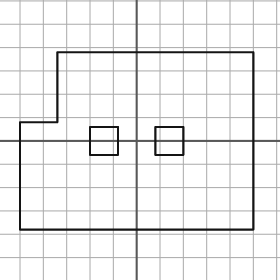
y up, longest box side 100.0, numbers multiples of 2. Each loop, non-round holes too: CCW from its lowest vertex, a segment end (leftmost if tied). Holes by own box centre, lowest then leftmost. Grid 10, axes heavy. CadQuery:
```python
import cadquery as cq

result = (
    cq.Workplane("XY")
    .moveTo(-50.0, -38.0)
    .lineTo(50.0, -38.0)
    .lineTo(50.0, 38.0)
    .lineTo(-34.0, 38.0)
    .lineTo(-34.0, 8.0)
    .lineTo(-50.0, 8.0)
    .close()
    .moveTo(-20.0, -6.0)
    .lineTo(-8.0, -6.0)
    .lineTo(-8.0, 6.0)
    .lineTo(-20.0, 6.0)
    .close()
    .moveTo(8.0, -6.0)
    .lineTo(20.0, -6.0)
    .lineTo(20.0, 6.0)
    .lineTo(8.0, 6.0)
    .close()
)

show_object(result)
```